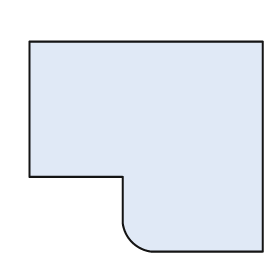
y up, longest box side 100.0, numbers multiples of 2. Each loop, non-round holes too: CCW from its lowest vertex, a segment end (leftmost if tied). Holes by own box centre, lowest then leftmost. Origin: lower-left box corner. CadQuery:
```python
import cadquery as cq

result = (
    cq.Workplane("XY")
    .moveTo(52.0, 0.0)
    .lineTo(100.0, 0.0)
    .lineTo(100.0, 90.0)
    .lineTo(0.0, 90.0)
    .lineTo(0.0, 32.0)
    .lineTo(40.0, 32.0)
    .lineTo(40.0, 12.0)
    .threePointArc((44.0, 4.0), (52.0, 0.0))
    .close()
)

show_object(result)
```